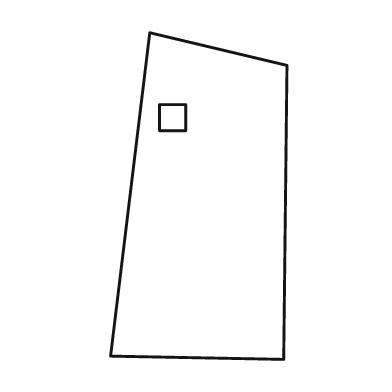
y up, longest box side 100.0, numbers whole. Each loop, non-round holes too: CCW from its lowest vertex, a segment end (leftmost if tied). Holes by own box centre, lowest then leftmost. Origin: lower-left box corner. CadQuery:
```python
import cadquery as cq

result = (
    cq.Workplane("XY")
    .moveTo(53.0, 0.0)
    .lineTo(54.0, 90.0)
    .lineTo(12.0, 100.0)
    .lineTo(0.0, 1.0)
    .close()
    .moveTo(15.0, 70.0)
    .lineTo(23.0, 70.0)
    .lineTo(23.0, 78.0)
    .lineTo(15.0, 78.0)
    .close()
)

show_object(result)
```